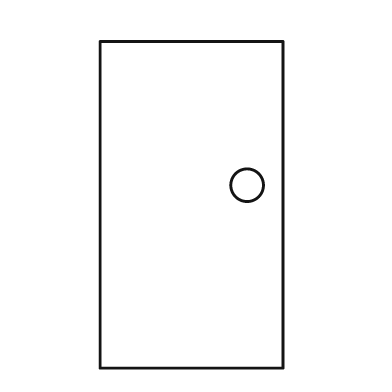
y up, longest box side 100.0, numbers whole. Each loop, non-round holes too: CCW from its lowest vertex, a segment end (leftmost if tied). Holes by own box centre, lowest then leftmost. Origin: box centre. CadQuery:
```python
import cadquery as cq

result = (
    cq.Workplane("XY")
    .moveTo(-28.0, -50.0)
    .lineTo(28.0, -50.0)
    .lineTo(28.0, 50.0)
    .lineTo(-28.0, 50.0)
    .close()
    .moveTo(17.0, 6.0)
    .circle(5.0)
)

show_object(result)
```